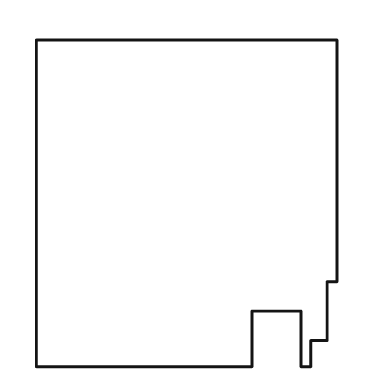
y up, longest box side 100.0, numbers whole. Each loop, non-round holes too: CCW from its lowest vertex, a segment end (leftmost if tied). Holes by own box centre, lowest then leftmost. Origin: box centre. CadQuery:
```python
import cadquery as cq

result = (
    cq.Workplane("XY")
    .moveTo(-46.0, -50.0)
    .lineTo(20.0, -50.0)
    .lineTo(20.0, -33.0)
    .lineTo(35.0, -33.0)
    .lineTo(35.0, -50.0)
    .lineTo(38.0, -50.0)
    .lineTo(38.0, -42.0)
    .lineTo(43.0, -42.0)
    .lineTo(43.0, -24.0)
    .lineTo(46.0, -24.0)
    .lineTo(46.0, 50.0)
    .lineTo(-46.0, 50.0)
    .close()
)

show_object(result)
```